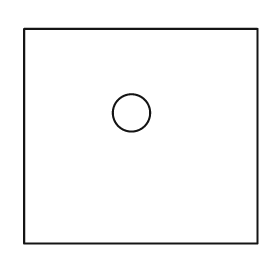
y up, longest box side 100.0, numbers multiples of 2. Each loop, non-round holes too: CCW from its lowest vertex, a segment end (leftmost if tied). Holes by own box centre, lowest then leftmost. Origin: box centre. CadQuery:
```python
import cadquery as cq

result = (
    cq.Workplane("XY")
    .moveTo(-50.0, -46.0)
    .lineTo(50.0, -46.0)
    .lineTo(50.0, 46.0)
    .lineTo(-50.0, 46.0)
    .close()
    .moveTo(-4.0, 10.0)
    .circle(8.0)
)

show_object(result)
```